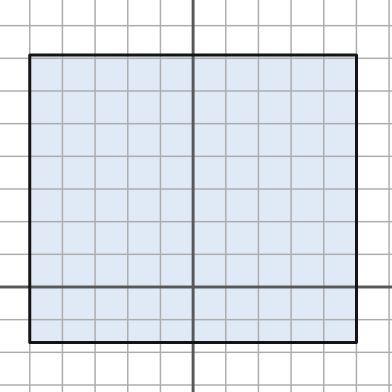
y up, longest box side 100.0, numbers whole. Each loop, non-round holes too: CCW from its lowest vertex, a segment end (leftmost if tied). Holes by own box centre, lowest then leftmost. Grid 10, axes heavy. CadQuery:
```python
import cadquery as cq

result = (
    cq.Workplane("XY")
    .moveTo(-50.0, -17.0)
    .lineTo(50.0, -17.0)
    .lineTo(50.0, 71.0)
    .lineTo(-50.0, 71.0)
    .close()
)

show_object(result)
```